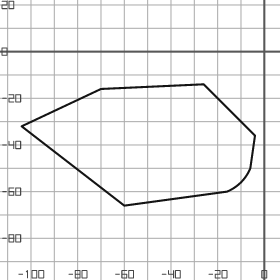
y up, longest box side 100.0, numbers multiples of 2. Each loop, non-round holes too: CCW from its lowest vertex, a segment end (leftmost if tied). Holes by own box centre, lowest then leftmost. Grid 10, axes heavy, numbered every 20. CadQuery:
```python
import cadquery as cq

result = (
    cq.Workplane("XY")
    .moveTo(-60.0, -66.0)
    .lineTo(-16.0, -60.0)
    .threePointArc((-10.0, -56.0), (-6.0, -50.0))
    .lineTo(-4.0, -36.0)
    .lineTo(-26.0, -14.0)
    .lineTo(-70.0, -16.0)
    .lineTo(-104.0, -32.0)
    .close()
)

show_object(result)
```